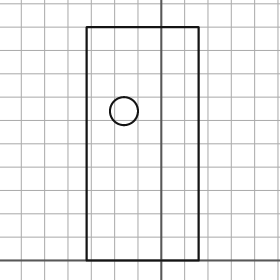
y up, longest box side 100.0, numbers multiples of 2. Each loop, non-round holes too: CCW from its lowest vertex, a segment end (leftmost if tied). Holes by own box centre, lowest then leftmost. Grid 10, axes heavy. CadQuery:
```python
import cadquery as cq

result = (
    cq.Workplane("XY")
    .moveTo(-32.0, 0.0)
    .lineTo(16.0, 0.0)
    .lineTo(16.0, 100.0)
    .lineTo(-32.0, 100.0)
    .close()
    .moveTo(-16.0, 64.0)
    .circle(6.0)
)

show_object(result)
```